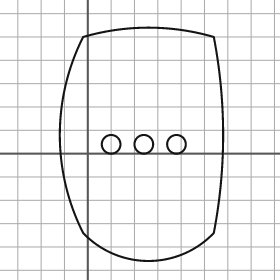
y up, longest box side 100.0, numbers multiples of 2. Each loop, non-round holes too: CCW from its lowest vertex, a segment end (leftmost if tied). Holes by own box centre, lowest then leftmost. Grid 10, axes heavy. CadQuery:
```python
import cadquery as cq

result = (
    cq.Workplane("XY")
    .moveTo(-2.0, -34.0)
    .threePointArc((26.0, -46.0), (54.0, -34.0))
    .threePointArc((58.0, 8.0), (54.0, 50.0))
    .threePointArc((26.0, 54.0), (-2.0, 50.0))
    .threePointArc((-12.0, 8.0), (-2.0, -34.0))
    .close()
    .moveTo(10.0, 4.0)
    .circle(4.0)
    .moveTo(24.0, 4.0)
    .circle(4.0)
    .moveTo(38.0, 4.0)
    .circle(4.0)
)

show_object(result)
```